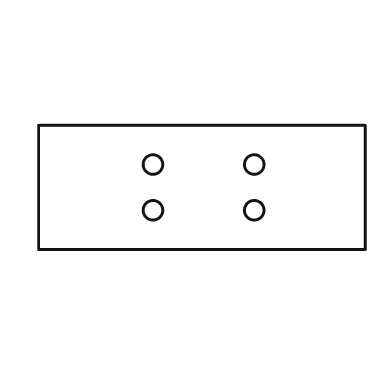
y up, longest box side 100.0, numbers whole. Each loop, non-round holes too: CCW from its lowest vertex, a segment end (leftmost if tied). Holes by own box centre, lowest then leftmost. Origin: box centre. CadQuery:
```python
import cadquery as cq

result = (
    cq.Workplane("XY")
    .moveTo(-50.0, -19.0)
    .lineTo(50.0, -19.0)
    .lineTo(50.0, 19.0)
    .lineTo(-50.0, 19.0)
    .close()
    .moveTo(-15.0, -7.0)
    .circle(3.0)
    .moveTo(16.0, -7.0)
    .circle(3.0)
    .moveTo(-15.0, 7.0)
    .circle(3.0)
    .moveTo(16.0, 7.0)
    .circle(3.0)
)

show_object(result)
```